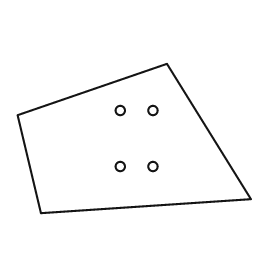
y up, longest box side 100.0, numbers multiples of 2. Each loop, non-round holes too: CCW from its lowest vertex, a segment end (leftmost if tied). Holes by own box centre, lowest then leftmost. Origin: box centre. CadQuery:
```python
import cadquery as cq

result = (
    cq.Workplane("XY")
    .moveTo(-40.0, -32.0)
    .lineTo(50.0, -26.0)
    .lineTo(14.0, 32.0)
    .lineTo(-50.0, 10.0)
    .close()
    .moveTo(-6.0, -12.0)
    .circle(2.0)
    .moveTo(8.0, -12.0)
    .circle(2.0)
    .moveTo(-6.0, 12.0)
    .circle(2.0)
    .moveTo(8.0, 12.0)
    .circle(2.0)
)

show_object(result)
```